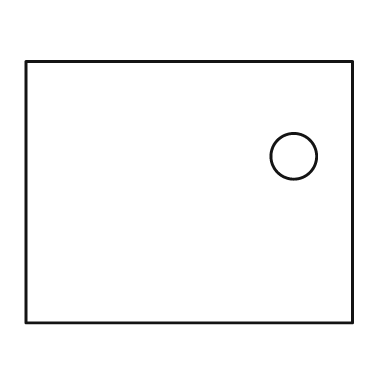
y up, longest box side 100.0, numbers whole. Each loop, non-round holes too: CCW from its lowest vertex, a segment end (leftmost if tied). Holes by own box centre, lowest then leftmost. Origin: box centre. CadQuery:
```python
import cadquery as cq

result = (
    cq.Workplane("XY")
    .moveTo(-50.0, -40.0)
    .lineTo(50.0, -40.0)
    .lineTo(50.0, 40.0)
    .lineTo(-50.0, 40.0)
    .close()
    .moveTo(32.0, 11.0)
    .circle(7.0)
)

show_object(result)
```